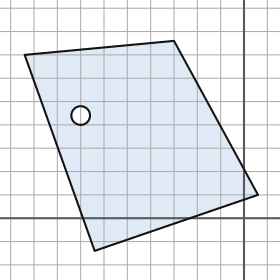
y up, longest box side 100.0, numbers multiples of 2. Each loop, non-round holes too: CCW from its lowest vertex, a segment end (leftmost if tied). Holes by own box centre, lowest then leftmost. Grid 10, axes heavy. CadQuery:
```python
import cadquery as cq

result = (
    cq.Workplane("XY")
    .moveTo(-64.0, -14.0)
    .lineTo(6.0, 10.0)
    .lineTo(-30.0, 76.0)
    .lineTo(-94.0, 70.0)
    .close()
    .moveTo(-70.0, 44.0)
    .circle(4.0)
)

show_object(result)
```